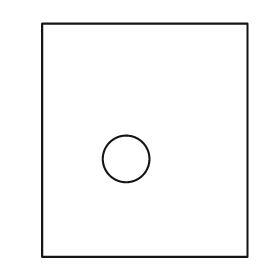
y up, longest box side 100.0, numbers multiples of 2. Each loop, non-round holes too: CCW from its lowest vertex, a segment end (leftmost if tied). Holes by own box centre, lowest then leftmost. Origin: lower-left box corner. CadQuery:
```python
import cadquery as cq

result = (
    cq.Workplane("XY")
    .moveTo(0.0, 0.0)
    .lineTo(88.0, 0.0)
    .lineTo(88.0, 100.0)
    .lineTo(0.0, 100.0)
    .close()
    .moveTo(36.0, 42.0)
    .circle(10.0)
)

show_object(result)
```